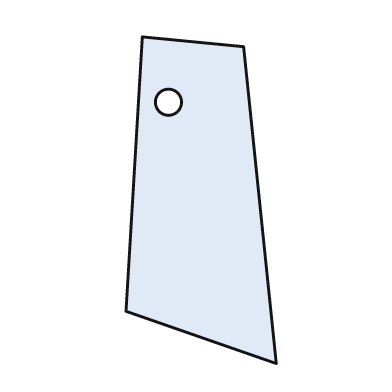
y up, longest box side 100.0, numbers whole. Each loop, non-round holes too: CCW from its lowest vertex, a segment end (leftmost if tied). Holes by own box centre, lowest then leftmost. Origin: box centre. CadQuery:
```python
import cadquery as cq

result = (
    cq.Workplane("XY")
    .moveTo(23.0, -50.0)
    .lineTo(13.0, 47.0)
    .lineTo(-18.0, 50.0)
    .lineTo(-23.0, -34.0)
    .close()
    .moveTo(-10.0, 30.0)
    .circle(4.0)
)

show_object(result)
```